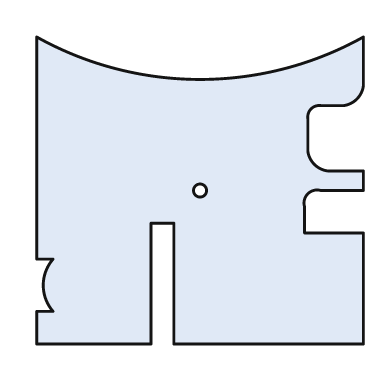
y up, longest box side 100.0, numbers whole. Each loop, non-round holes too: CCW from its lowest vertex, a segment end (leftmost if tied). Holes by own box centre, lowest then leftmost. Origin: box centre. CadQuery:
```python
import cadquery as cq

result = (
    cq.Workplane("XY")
    .moveTo(-50.0, -47.0)
    .lineTo(-15.0, -47.0)
    .lineTo(-15.0, -10.0)
    .lineTo(-8.0, -10.0)
    .lineTo(-8.0, -47.0)
    .lineTo(50.0, -47.0)
    .lineTo(50.0, -13.0)
    .lineTo(32.0, -13.0)
    .lineTo(32.0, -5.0)
    .threePointArc((33.0, -1.0), (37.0, 0.0))
    .lineTo(50.0, 0.0)
    .lineTo(50.0, 6.0)
    .lineTo(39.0, 6.0)
    .threePointArc((35.0, 8.0), (33.0, 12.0))
    .lineTo(33.0, 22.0)
    .threePointArc((34.0, 25.0), (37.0, 26.0))
    .lineTo(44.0, 26.0)
    .threePointArc((48.0, 28.0), (50.0, 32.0))
    .lineTo(50.0, 47.0)
    .threePointArc((0.0, 34.0), (-50.0, 47.0))
    .lineTo(-50.0, -21.0)
    .lineTo(-45.0, -21.0)
    .threePointArc((-48.0, -29.0), (-45.0, -37.0))
    .lineTo(-50.0, -37.0)
    .close()
    .moveTo(0.0, 0.0)
    .circle(2.0)
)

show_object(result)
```